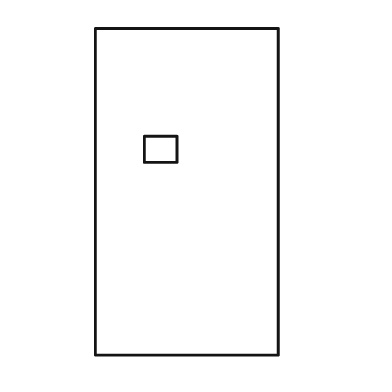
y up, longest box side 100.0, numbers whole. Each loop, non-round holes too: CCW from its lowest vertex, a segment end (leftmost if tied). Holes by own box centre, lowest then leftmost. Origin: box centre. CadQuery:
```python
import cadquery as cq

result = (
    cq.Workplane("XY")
    .moveTo(-28.0, -50.0)
    .lineTo(28.0, -50.0)
    .lineTo(28.0, 50.0)
    .lineTo(-28.0, 50.0)
    .close()
    .moveTo(-13.0, 9.0)
    .lineTo(-3.0, 9.0)
    .lineTo(-3.0, 17.0)
    .lineTo(-13.0, 17.0)
    .close()
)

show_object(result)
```